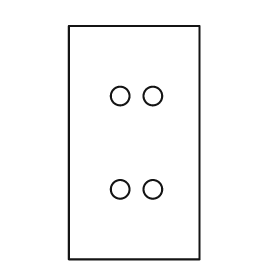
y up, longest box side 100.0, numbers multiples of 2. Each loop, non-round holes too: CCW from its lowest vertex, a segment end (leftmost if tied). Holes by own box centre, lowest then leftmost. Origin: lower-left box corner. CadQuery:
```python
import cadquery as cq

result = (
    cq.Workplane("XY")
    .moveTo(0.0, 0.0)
    .lineTo(56.0, 0.0)
    .lineTo(56.0, 100.0)
    .lineTo(0.0, 100.0)
    .close()
    .moveTo(22.0, 30.0)
    .circle(4.0)
    .moveTo(36.0, 30.0)
    .circle(4.0)
    .moveTo(22.0, 70.0)
    .circle(4.0)
    .moveTo(36.0, 70.0)
    .circle(4.0)
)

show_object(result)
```